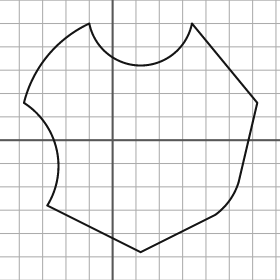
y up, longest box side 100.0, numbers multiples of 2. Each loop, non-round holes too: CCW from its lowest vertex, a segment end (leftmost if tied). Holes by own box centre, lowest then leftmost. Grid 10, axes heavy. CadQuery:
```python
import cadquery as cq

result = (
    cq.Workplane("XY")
    .moveTo(12.0, -48.0)
    .lineTo(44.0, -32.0)
    .threePointArc((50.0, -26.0), (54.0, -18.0))
    .lineTo(62.0, 16.0)
    .lineTo(34.0, 50.0)
    .threePointArc((12.0, 32.0), (-10.0, 50.0))
    .threePointArc((-28.0, 36.0), (-38.0, 16.0))
    .threePointArc((-24.0, -4.0), (-28.0, -28.0))
    .close()
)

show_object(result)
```